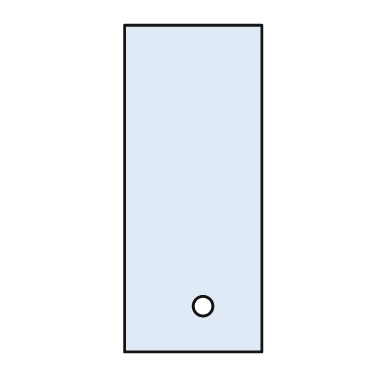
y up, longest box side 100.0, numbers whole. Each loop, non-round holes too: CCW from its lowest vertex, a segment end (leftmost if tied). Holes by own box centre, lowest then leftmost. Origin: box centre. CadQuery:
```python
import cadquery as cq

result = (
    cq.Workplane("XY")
    .moveTo(-21.0, -50.0)
    .lineTo(21.0, -50.0)
    .lineTo(21.0, 50.0)
    .lineTo(-21.0, 50.0)
    .close()
    .moveTo(3.0, -36.0)
    .circle(3.0)
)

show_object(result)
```